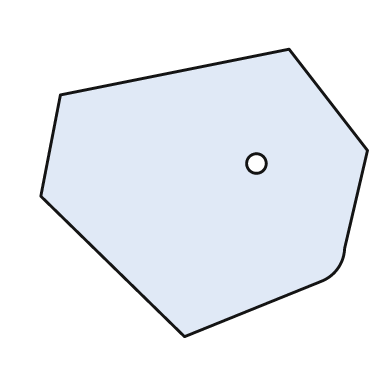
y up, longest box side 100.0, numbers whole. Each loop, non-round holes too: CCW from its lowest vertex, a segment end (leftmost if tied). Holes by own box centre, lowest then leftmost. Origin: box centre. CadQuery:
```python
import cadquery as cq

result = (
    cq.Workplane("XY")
    .moveTo(-6.0, -44.0)
    .lineTo(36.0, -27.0)
    .threePointArc((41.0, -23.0), (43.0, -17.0))
    .lineTo(50.0, 13.0)
    .lineTo(26.0, 44.0)
    .lineTo(-44.0, 30.0)
    .lineTo(-50.0, -1.0)
    .close()
    .moveTo(16.0, 9.0)
    .circle(3.0)
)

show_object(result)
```